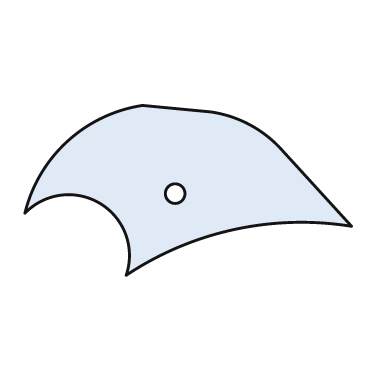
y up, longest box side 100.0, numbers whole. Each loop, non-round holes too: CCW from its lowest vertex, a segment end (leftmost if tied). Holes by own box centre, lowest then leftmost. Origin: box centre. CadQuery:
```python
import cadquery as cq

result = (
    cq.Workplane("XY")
    .moveTo(-19.0, -26.0)
    .threePointArc((14.0, -12.0), (50.0, -11.0))
    .lineTo(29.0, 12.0)
    .threePointArc((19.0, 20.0), (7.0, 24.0))
    .lineTo(-14.0, 26.0)
    .threePointArc((-37.0, 15.0), (-50.0, -7.0))
    .threePointArc((-27.0, -4.0), (-19.0, -26.0))
    .close()
    .moveTo(-4.0, -1.0)
    .circle(3.0)
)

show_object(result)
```